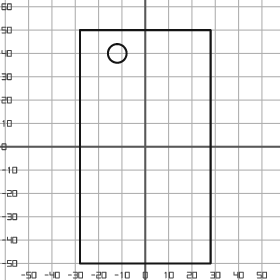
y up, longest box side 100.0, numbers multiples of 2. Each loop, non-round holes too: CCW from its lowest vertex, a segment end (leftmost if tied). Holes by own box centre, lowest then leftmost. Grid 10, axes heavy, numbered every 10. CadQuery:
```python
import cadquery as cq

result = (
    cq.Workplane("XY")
    .moveTo(-28.0, -50.0)
    .lineTo(28.0, -50.0)
    .lineTo(28.0, 50.0)
    .lineTo(-28.0, 50.0)
    .close()
    .moveTo(-12.0, 40.0)
    .circle(4.0)
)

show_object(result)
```